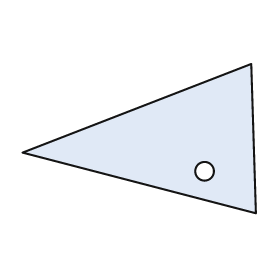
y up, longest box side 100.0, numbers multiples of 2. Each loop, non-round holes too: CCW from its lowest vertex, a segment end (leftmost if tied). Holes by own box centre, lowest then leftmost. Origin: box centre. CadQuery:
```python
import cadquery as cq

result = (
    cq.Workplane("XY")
    .moveTo(50.0, -32.0)
    .lineTo(48.0, 32.0)
    .lineTo(-50.0, -6.0)
    .close()
    .moveTo(28.0, -14.0)
    .circle(4.0)
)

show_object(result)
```